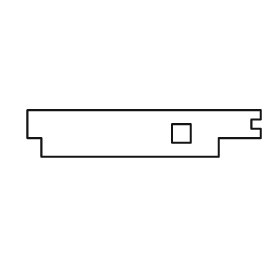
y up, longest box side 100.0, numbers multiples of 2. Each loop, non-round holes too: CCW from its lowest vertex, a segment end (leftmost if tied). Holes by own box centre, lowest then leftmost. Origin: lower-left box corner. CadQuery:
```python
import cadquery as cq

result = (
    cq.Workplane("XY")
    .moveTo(6.0, 0.0)
    .lineTo(82.0, 0.0)
    .lineTo(82.0, 8.0)
    .lineTo(100.0, 8.0)
    .lineTo(100.0, 12.0)
    .lineTo(96.0, 12.0)
    .lineTo(96.0, 16.0)
    .lineTo(100.0, 16.0)
    .lineTo(100.0, 20.0)
    .lineTo(0.0, 20.0)
    .lineTo(0.0, 8.0)
    .lineTo(6.0, 8.0)
    .close()
    .moveTo(62.0, 6.0)
    .lineTo(70.0, 6.0)
    .lineTo(70.0, 14.0)
    .lineTo(62.0, 14.0)
    .close()
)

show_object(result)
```